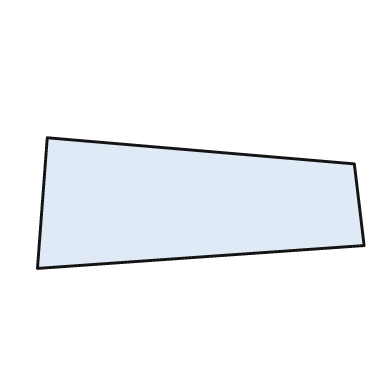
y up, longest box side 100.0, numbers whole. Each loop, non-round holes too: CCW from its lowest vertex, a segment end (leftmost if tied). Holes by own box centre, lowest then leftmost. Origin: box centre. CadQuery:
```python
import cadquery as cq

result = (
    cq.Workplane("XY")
    .moveTo(-50.0, -20.0)
    .lineTo(50.0, -13.0)
    .lineTo(47.0, 12.0)
    .lineTo(-47.0, 20.0)
    .close()
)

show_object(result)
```